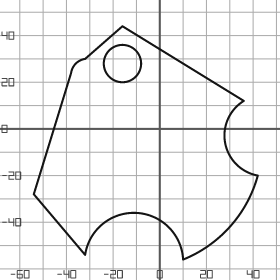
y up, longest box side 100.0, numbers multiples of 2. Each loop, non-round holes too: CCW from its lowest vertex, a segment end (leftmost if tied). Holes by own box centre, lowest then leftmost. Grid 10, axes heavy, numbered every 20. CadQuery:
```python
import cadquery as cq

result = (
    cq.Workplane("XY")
    .moveTo(10.0, -56.0)
    .threePointArc((30.0, -42.0), (42.0, -20.0))
    .threePointArc((28.0, -6.0), (36.0, 12.0))
    .lineTo(-16.0, 44.0)
    .lineTo(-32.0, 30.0)
    .threePointArc((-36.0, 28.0), (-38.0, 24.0))
    .lineTo(-54.0, -28.0)
    .lineTo(-32.0, -54.0)
    .threePointArc((-10.0, -36.0), (10.0, -56.0))
    .close()
    .moveTo(-16.0, 28.0)
    .circle(8.0)
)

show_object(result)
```